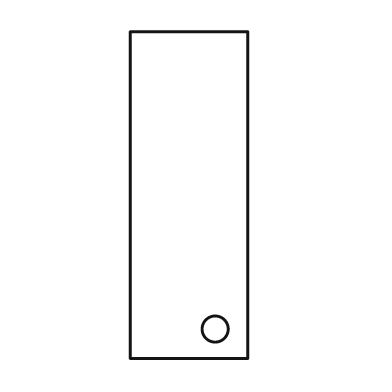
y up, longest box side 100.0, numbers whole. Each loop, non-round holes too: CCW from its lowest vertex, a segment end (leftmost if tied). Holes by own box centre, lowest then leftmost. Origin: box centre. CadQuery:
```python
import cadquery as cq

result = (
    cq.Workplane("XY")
    .moveTo(-18.0, -50.0)
    .lineTo(18.0, -50.0)
    .lineTo(18.0, 50.0)
    .lineTo(-18.0, 50.0)
    .close()
    .moveTo(8.0, -41.0)
    .circle(4.0)
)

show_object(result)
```